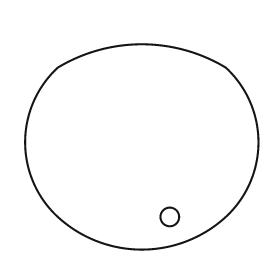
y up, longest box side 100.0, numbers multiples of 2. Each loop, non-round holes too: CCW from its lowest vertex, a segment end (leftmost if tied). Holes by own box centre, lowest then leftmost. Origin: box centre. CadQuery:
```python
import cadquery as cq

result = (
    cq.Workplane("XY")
    .moveTo(-36.0, -30.0)
    .threePointArc((0.0, -44.0), (36.0, -30.0))
    .threePointArc((50.0, 2.0), (36.0, 34.0))
    .threePointArc((0.0, 44.0), (-36.0, 34.0))
    .threePointArc((-50.0, 2.0), (-36.0, -30.0))
    .close()
    .moveTo(12.0, -30.0)
    .circle(4.0)
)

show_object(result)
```